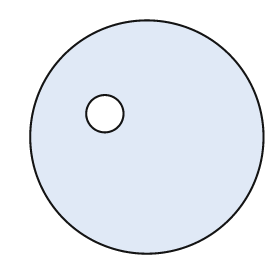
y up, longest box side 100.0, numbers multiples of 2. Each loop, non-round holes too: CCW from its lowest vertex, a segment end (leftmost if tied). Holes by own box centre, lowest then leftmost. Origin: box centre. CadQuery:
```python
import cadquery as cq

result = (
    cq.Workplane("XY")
    .moveTo(0.0, 0.0)
    .circle(50.0)
    .moveTo(-18.0, 10.0)
    .circle(8.0)
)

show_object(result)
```